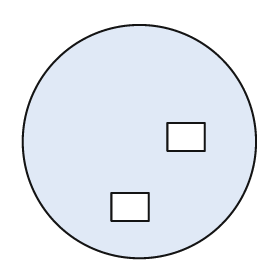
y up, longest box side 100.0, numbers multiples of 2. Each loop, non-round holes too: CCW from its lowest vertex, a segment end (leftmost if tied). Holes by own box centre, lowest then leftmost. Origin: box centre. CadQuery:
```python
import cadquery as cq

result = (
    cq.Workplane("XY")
    .moveTo(0.0, 0.0)
    .circle(50.0)
    .moveTo(-12.0, -34.0)
    .lineTo(4.0, -34.0)
    .lineTo(4.0, -22.0)
    .lineTo(-12.0, -22.0)
    .close()
    .moveTo(12.0, -4.0)
    .lineTo(28.0, -4.0)
    .lineTo(28.0, 8.0)
    .lineTo(12.0, 8.0)
    .close()
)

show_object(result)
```